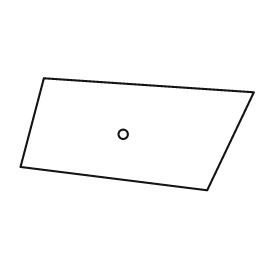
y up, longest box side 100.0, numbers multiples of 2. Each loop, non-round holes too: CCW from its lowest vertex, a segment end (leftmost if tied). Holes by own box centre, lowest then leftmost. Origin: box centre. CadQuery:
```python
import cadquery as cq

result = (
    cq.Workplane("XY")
    .moveTo(30.0, -24.0)
    .lineTo(50.0, 18.0)
    .lineTo(-40.0, 24.0)
    .lineTo(-50.0, -14.0)
    .close()
    .moveTo(-6.0, 0.0)
    .circle(2.0)
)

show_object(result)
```